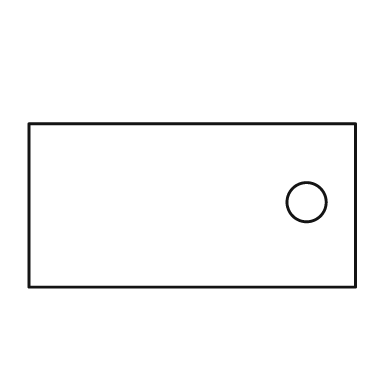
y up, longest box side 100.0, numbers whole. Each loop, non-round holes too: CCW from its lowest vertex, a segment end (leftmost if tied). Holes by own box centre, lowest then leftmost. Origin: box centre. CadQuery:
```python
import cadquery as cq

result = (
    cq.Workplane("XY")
    .moveTo(-50.0, -25.0)
    .lineTo(50.0, -25.0)
    .lineTo(50.0, 25.0)
    .lineTo(-50.0, 25.0)
    .close()
    .moveTo(35.0, 1.0)
    .circle(6.0)
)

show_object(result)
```